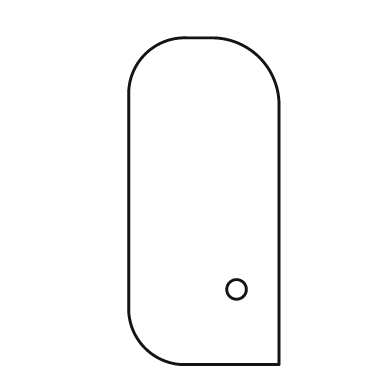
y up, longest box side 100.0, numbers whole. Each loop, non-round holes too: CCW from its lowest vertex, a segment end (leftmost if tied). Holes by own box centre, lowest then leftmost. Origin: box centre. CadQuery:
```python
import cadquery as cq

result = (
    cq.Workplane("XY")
    .moveTo(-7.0, -50.0)
    .lineTo(23.0, -50.0)
    .lineTo(23.0, 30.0)
    .threePointArc((17.0, 44.0), (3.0, 50.0))
    .lineTo(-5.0, 50.0)
    .threePointArc((-18.0, 45.0), (-23.0, 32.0))
    .lineTo(-23.0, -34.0)
    .threePointArc((-18.0, -45.0), (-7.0, -50.0))
    .close()
    .moveTo(10.0, -27.0)
    .circle(3.0)
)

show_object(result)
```